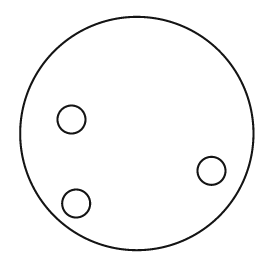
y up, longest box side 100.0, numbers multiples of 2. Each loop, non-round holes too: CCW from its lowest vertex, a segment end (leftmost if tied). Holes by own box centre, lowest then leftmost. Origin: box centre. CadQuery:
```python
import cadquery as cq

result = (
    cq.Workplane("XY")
    .moveTo(0.0, 0.0)
    .circle(50.0)
    .moveTo(-26.0, -30.0)
    .circle(6.0)
    .moveTo(32.0, -16.0)
    .circle(6.0)
    .moveTo(-28.0, 6.0)
    .circle(6.0)
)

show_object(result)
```